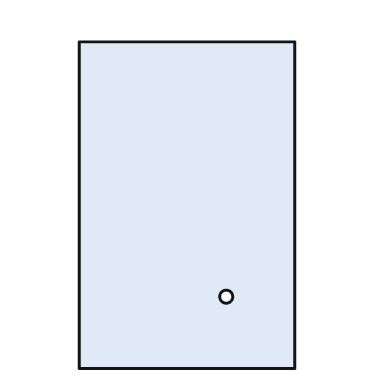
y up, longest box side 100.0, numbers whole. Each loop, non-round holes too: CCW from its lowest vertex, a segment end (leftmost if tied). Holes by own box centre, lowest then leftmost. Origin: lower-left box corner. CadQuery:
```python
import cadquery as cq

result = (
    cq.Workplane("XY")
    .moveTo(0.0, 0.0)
    .lineTo(66.0, 0.0)
    .lineTo(66.0, 100.0)
    .lineTo(0.0, 100.0)
    .close()
    .moveTo(45.0, 22.0)
    .circle(2.0)
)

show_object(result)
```